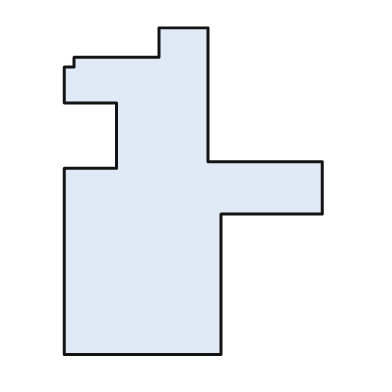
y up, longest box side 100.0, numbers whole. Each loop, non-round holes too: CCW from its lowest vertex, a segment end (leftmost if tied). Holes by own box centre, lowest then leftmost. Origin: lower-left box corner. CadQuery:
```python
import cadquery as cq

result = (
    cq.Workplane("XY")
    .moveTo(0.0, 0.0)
    .lineTo(48.0, 0.0)
    .lineTo(48.0, 43.0)
    .lineTo(79.0, 43.0)
    .lineTo(79.0, 59.0)
    .lineTo(44.0, 59.0)
    .lineTo(44.0, 100.0)
    .lineTo(29.0, 100.0)
    .lineTo(29.0, 91.0)
    .lineTo(3.0, 91.0)
    .lineTo(3.0, 88.0)
    .lineTo(0.0, 88.0)
    .lineTo(0.0, 77.0)
    .lineTo(16.0, 77.0)
    .lineTo(16.0, 57.0)
    .lineTo(0.0, 57.0)
    .close()
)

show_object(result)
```